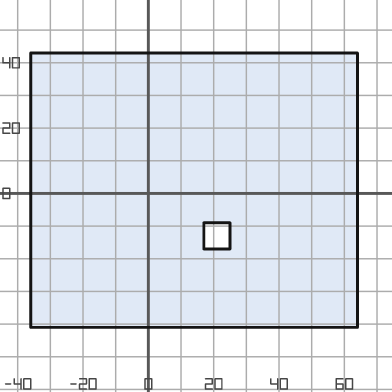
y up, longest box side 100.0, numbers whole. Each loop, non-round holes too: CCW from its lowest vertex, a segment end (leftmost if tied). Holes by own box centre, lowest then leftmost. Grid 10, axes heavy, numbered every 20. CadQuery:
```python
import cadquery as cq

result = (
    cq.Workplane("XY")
    .moveTo(-36.0, -41.0)
    .lineTo(64.0, -41.0)
    .lineTo(64.0, 43.0)
    .lineTo(-36.0, 43.0)
    .close()
    .moveTo(17.0, -17.0)
    .lineTo(25.0, -17.0)
    .lineTo(25.0, -9.0)
    .lineTo(17.0, -9.0)
    .close()
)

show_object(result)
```